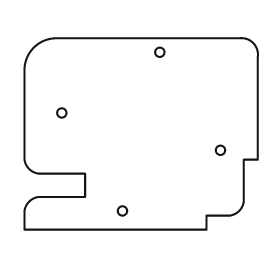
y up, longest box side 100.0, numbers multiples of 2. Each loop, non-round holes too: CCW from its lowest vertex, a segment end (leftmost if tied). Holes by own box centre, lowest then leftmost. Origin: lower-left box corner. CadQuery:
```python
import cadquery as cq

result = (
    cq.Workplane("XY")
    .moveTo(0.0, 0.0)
    .lineTo(78.0, 0.0)
    .lineTo(78.0, 6.0)
    .lineTo(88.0, 6.0)
    .threePointArc((92.0, 8.0), (94.0, 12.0))
    .lineTo(94.0, 30.0)
    .lineTo(100.0, 30.0)
    .lineTo(100.0, 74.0)
    .threePointArc((98.0, 80.0), (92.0, 82.0))
    .lineTo(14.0, 82.0)
    .threePointArc((4.0, 78.0), (0.0, 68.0))
    .lineTo(0.0, 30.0)
    .threePointArc((2.0, 26.0), (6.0, 24.0))
    .lineTo(26.0, 24.0)
    .lineTo(26.0, 14.0)
    .lineTo(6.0, 14.0)
    .threePointArc((2.0, 12.0), (0.0, 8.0))
    .close()
    .moveTo(42.0, 8.0)
    .circle(2.0)
    .moveTo(84.0, 34.0)
    .circle(2.0)
    .moveTo(16.0, 50.0)
    .circle(2.0)
    .moveTo(58.0, 76.0)
    .circle(2.0)
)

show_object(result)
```